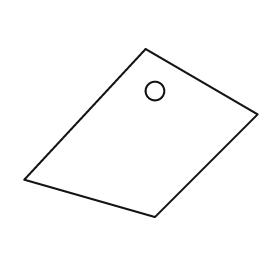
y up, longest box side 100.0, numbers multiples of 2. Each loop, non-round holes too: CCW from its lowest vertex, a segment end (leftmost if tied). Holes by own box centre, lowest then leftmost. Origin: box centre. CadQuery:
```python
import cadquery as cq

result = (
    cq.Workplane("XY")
    .moveTo(6.0, -36.0)
    .lineTo(50.0, 8.0)
    .lineTo(2.0, 36.0)
    .lineTo(-50.0, -20.0)
    .close()
    .moveTo(6.0, 18.0)
    .circle(4.0)
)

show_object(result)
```